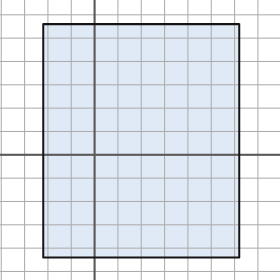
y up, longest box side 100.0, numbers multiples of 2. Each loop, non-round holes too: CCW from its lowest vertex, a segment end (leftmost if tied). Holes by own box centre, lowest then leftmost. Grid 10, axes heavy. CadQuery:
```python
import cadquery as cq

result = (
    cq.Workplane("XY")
    .moveTo(-22.0, -44.0)
    .lineTo(62.0, -44.0)
    .lineTo(62.0, 56.0)
    .lineTo(-22.0, 56.0)
    .close()
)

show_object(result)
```